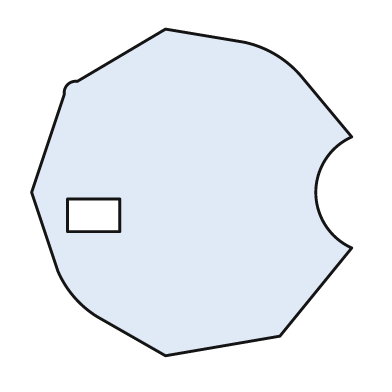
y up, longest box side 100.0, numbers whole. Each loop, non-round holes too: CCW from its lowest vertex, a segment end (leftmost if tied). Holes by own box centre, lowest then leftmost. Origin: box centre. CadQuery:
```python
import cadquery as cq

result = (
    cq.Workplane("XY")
    .moveTo(-8.0, -50.0)
    .lineTo(27.0, -44.0)
    .lineTo(49.0, -17.0)
    .threePointArc((38.0, 0.0), (49.0, 17.0))
    .lineTo(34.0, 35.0)
    .threePointArc((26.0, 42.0), (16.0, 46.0))
    .lineTo(-8.0, 50.0)
    .lineTo(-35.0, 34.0)
    .threePointArc((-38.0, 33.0), (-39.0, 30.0))
    .lineTo(-49.0, 0.0)
    .lineTo(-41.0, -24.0)
    .threePointArc((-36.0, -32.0), (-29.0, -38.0))
    .close()
    .moveTo(-38.0, -12.0)
    .lineTo(-22.0, -12.0)
    .lineTo(-22.0, -2.0)
    .lineTo(-38.0, -2.0)
    .close()
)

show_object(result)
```